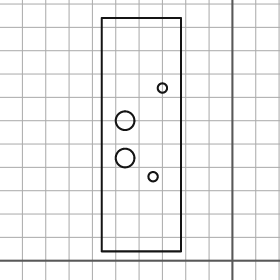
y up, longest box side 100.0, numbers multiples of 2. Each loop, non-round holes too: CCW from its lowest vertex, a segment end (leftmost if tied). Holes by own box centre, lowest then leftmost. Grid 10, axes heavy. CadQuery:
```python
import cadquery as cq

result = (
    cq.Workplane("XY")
    .moveTo(-56.0, 4.0)
    .lineTo(-22.0, 4.0)
    .lineTo(-22.0, 104.0)
    .lineTo(-56.0, 104.0)
    .close()
    .moveTo(-34.0, 36.0)
    .circle(2.0)
    .moveTo(-46.0, 44.0)
    .circle(4.0)
    .moveTo(-46.0, 60.0)
    .circle(4.0)
    .moveTo(-30.0, 74.0)
    .circle(2.0)
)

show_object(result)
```